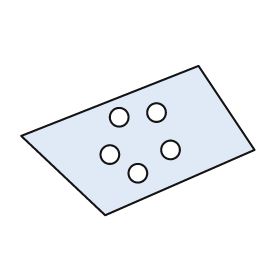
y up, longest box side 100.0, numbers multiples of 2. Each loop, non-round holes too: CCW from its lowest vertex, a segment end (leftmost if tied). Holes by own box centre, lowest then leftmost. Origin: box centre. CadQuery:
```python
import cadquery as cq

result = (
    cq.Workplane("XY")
    .moveTo(-14.0, -32.0)
    .lineTo(50.0, -4.0)
    .lineTo(26.0, 32.0)
    .lineTo(-50.0, 2.0)
    .close()
    .moveTo(0.0, -14.0)
    .circle(4.0)
    .moveTo(-12.0, -6.0)
    .circle(4.0)
    .moveTo(14.0, -4.0)
    .circle(4.0)
    .moveTo(-8.0, 10.0)
    .circle(4.0)
    .moveTo(8.0, 12.0)
    .circle(4.0)
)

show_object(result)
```